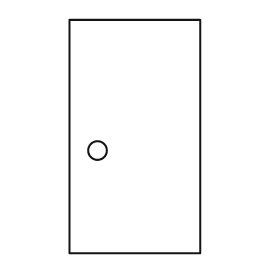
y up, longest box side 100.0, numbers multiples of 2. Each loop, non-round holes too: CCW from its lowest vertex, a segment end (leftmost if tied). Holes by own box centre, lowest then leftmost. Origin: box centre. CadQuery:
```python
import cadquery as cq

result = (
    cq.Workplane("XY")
    .moveTo(-28.0, -50.0)
    .lineTo(28.0, -50.0)
    .lineTo(28.0, 50.0)
    .lineTo(-28.0, 50.0)
    .close()
    .moveTo(-16.0, -6.0)
    .circle(4.0)
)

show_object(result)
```